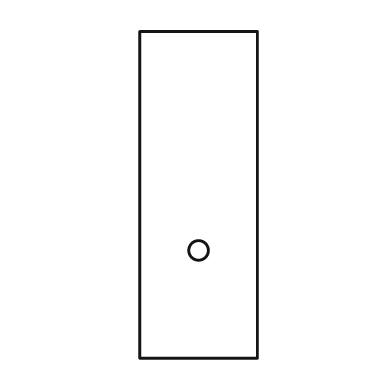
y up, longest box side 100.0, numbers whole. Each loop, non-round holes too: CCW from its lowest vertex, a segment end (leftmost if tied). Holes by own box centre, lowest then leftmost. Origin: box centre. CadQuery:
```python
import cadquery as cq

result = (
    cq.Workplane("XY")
    .moveTo(-18.0, -50.0)
    .lineTo(18.0, -50.0)
    .lineTo(18.0, 50.0)
    .lineTo(-18.0, 50.0)
    .close()
    .moveTo(0.0, -17.0)
    .circle(3.0)
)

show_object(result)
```